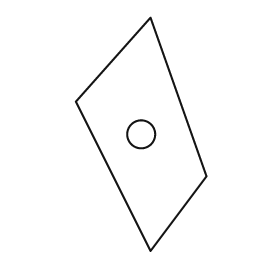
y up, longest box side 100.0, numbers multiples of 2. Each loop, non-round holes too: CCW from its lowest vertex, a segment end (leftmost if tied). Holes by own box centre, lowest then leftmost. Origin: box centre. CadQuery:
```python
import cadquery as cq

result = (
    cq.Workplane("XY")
    .moveTo(4.0, -50.0)
    .lineTo(28.0, -18.0)
    .lineTo(4.0, 50.0)
    .lineTo(-28.0, 14.0)
    .close()
    .moveTo(0.0, 0.0)
    .circle(6.0)
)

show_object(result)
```